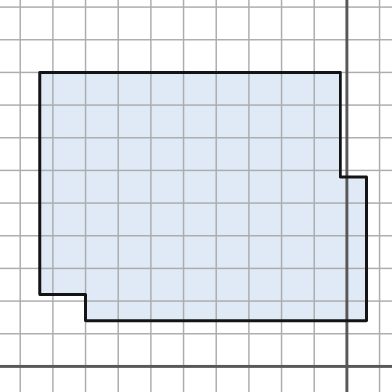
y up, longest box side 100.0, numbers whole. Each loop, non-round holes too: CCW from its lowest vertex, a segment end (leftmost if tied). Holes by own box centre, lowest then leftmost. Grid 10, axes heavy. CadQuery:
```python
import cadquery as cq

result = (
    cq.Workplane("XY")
    .moveTo(-80.0, 14.0)
    .lineTo(6.0, 14.0)
    .lineTo(6.0, 58.0)
    .lineTo(-2.0, 58.0)
    .lineTo(-2.0, 90.0)
    .lineTo(-94.0, 90.0)
    .lineTo(-94.0, 22.0)
    .lineTo(-80.0, 22.0)
    .close()
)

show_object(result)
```